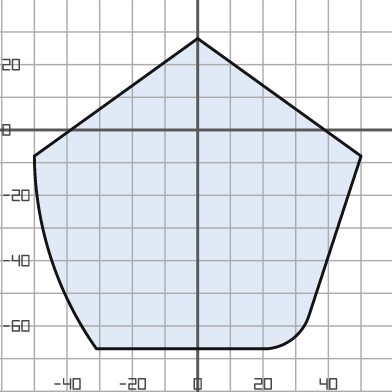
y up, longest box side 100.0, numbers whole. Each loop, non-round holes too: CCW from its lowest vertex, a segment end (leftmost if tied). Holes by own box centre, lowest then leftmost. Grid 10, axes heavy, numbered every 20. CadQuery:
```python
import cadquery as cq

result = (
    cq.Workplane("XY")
    .moveTo(-31.0, -67.0)
    .lineTo(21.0, -67.0)
    .threePointArc((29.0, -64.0), (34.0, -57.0))
    .lineTo(50.0, -8.0)
    .lineTo(0.0, 28.0)
    .lineTo(-50.0, -8.0)
    .threePointArc((-45.0, -39.0), (-31.0, -67.0))
    .close()
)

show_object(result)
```